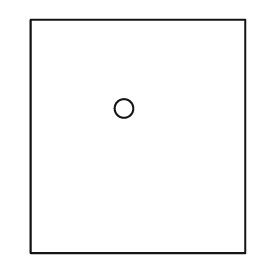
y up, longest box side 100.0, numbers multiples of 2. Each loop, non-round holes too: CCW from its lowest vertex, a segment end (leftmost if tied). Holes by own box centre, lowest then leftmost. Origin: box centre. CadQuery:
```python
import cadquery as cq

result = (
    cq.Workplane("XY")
    .moveTo(-46.0, -50.0)
    .lineTo(46.0, -50.0)
    .lineTo(46.0, 50.0)
    .lineTo(-46.0, 50.0)
    .close()
    .moveTo(-6.0, 12.0)
    .circle(4.0)
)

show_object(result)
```